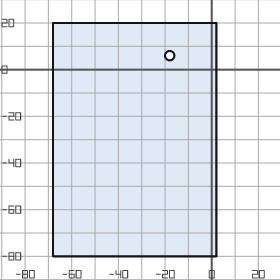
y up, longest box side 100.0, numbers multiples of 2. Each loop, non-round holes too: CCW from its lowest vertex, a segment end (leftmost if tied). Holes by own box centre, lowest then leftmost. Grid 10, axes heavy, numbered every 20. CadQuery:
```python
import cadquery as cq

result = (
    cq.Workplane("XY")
    .moveTo(-68.0, -80.0)
    .lineTo(2.0, -80.0)
    .lineTo(2.0, 20.0)
    .lineTo(-68.0, 20.0)
    .close()
    .moveTo(-18.0, 6.0)
    .circle(2.0)
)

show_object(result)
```